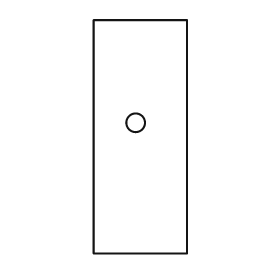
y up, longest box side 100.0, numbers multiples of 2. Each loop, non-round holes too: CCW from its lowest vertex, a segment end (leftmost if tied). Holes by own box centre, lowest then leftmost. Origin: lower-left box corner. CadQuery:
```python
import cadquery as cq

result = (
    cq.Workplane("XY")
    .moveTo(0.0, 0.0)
    .lineTo(40.0, 0.0)
    .lineTo(40.0, 100.0)
    .lineTo(0.0, 100.0)
    .close()
    .moveTo(18.0, 56.0)
    .circle(4.0)
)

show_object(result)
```